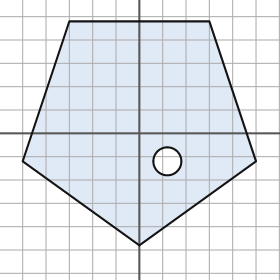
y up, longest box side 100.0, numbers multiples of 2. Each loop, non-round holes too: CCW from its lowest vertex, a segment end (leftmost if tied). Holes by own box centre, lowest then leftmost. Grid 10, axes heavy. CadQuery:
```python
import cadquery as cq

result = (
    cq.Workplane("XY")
    .moveTo(0.0, -48.0)
    .lineTo(50.0, -12.0)
    .lineTo(30.0, 48.0)
    .lineTo(-30.0, 48.0)
    .lineTo(-50.0, -12.0)
    .close()
    .moveTo(12.0, -12.0)
    .circle(6.0)
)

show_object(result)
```